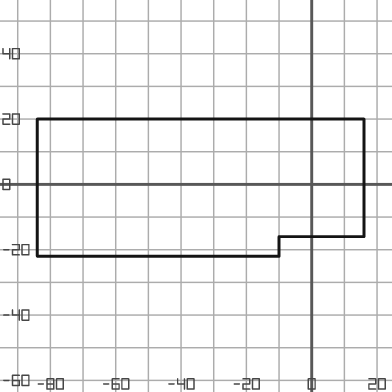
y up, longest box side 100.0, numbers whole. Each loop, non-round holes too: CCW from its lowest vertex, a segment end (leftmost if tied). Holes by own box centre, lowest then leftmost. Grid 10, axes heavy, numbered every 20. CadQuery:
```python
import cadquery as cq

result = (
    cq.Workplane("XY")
    .moveTo(-84.0, -22.0)
    .lineTo(-10.0, -22.0)
    .lineTo(-10.0, -16.0)
    .lineTo(16.0, -16.0)
    .lineTo(16.0, 20.0)
    .lineTo(-84.0, 20.0)
    .close()
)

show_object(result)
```